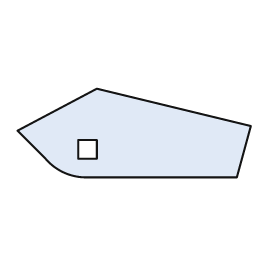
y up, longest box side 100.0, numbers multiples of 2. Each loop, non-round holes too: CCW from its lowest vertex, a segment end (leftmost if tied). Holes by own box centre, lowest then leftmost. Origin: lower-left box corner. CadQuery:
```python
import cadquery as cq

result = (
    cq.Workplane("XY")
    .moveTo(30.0, 0.0)
    .lineTo(94.0, 0.0)
    .lineTo(100.0, 22.0)
    .lineTo(34.0, 38.0)
    .lineTo(0.0, 20.0)
    .lineTo(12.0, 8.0)
    .threePointArc((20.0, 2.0), (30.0, 0.0))
    .close()
    .moveTo(26.0, 8.0)
    .lineTo(34.0, 8.0)
    .lineTo(34.0, 16.0)
    .lineTo(26.0, 16.0)
    .close()
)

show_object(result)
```